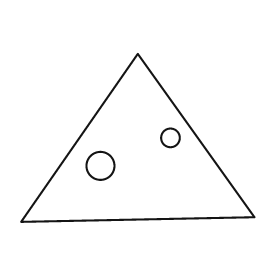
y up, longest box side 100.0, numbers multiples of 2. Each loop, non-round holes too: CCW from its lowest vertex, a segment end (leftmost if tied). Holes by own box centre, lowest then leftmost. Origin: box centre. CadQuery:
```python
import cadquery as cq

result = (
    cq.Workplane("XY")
    .moveTo(-50.0, -36.0)
    .lineTo(50.0, -34.0)
    .lineTo(0.0, 36.0)
    .close()
    .moveTo(-16.0, -12.0)
    .circle(6.0)
    .moveTo(14.0, 0.0)
    .circle(4.0)
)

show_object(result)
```